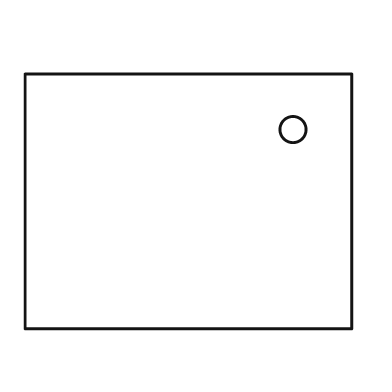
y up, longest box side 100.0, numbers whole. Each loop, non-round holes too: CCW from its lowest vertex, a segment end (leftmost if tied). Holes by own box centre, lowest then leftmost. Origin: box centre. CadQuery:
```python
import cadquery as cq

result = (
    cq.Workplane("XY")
    .moveTo(-50.0, -39.0)
    .lineTo(50.0, -39.0)
    .lineTo(50.0, 39.0)
    .lineTo(-50.0, 39.0)
    .close()
    .moveTo(32.0, 22.0)
    .circle(4.0)
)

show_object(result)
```